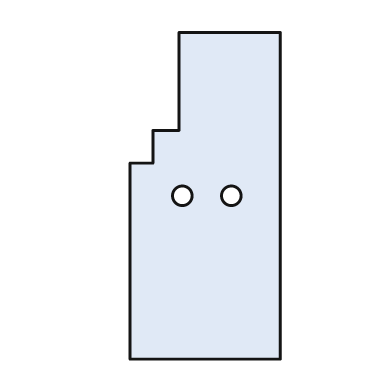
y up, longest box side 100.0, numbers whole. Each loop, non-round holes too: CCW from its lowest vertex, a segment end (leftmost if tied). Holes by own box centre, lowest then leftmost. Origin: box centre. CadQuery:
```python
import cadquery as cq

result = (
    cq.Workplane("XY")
    .moveTo(-23.0, -50.0)
    .lineTo(23.0, -50.0)
    .lineTo(23.0, 50.0)
    .lineTo(-8.0, 50.0)
    .lineTo(-8.0, 20.0)
    .lineTo(-16.0, 20.0)
    .lineTo(-16.0, 10.0)
    .lineTo(-23.0, 10.0)
    .close()
    .moveTo(-7.0, 0.0)
    .circle(3.0)
    .moveTo(8.0, 0.0)
    .circle(3.0)
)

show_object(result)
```